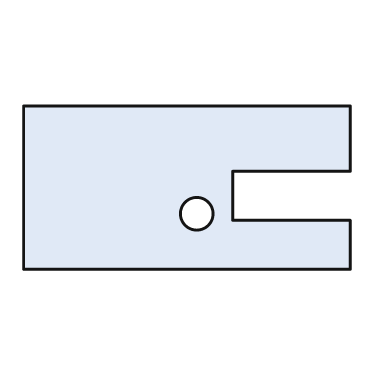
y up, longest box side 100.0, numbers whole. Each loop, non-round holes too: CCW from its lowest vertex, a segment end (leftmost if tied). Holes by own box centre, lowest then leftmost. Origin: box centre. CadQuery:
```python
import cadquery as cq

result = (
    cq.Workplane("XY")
    .moveTo(-50.0, -25.0)
    .lineTo(50.0, -25.0)
    .lineTo(50.0, -10.0)
    .lineTo(14.0, -10.0)
    .lineTo(14.0, 5.0)
    .lineTo(50.0, 5.0)
    .lineTo(50.0, 25.0)
    .lineTo(-50.0, 25.0)
    .close()
    .moveTo(3.0, -8.0)
    .circle(5.0)
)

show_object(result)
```